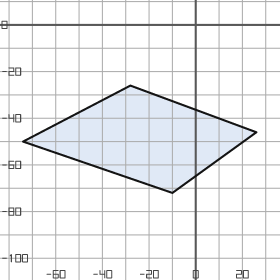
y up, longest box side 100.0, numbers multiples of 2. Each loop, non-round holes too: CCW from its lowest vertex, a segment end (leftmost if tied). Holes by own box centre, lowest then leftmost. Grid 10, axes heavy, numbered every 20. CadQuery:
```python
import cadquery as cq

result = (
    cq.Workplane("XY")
    .moveTo(-10.0, -72.0)
    .lineTo(26.0, -46.0)
    .lineTo(-28.0, -26.0)
    .lineTo(-74.0, -50.0)
    .close()
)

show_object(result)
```